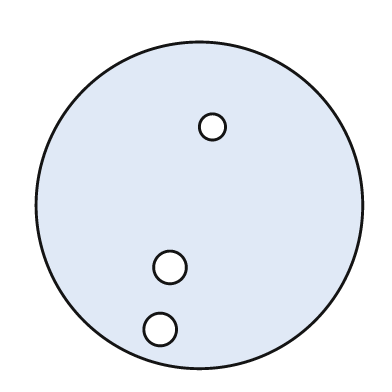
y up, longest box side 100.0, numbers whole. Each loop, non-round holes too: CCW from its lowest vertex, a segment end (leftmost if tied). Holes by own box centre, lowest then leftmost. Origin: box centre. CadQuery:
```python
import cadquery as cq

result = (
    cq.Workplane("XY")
    .moveTo(0.0, 0.0)
    .circle(50.0)
    .moveTo(-12.0, -38.0)
    .circle(5.0)
    .moveTo(-9.0, -19.0)
    .circle(5.0)
    .moveTo(4.0, 24.0)
    .circle(4.0)
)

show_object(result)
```